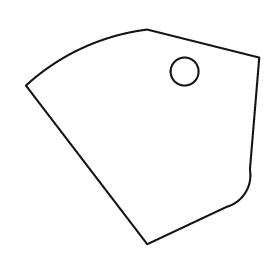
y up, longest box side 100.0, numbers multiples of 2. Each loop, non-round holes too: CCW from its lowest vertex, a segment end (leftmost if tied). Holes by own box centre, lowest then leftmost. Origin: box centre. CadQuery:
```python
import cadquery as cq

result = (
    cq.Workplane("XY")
    .moveTo(2.0, -46.0)
    .lineTo(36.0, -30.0)
    .threePointArc((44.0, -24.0), (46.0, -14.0))
    .lineTo(50.0, 34.0)
    .lineTo(2.0, 46.0)
    .threePointArc((-26.0, 38.0), (-50.0, 22.0))
    .close()
    .moveTo(18.0, 28.0)
    .circle(6.0)
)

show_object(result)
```